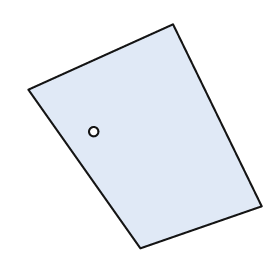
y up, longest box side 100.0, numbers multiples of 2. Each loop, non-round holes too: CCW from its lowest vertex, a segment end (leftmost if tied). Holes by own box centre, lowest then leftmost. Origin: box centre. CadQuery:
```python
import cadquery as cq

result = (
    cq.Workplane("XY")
    .moveTo(-2.0, -48.0)
    .lineTo(50.0, -30.0)
    .lineTo(12.0, 48.0)
    .lineTo(-50.0, 20.0)
    .close()
    .moveTo(-22.0, 2.0)
    .circle(2.0)
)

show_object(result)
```